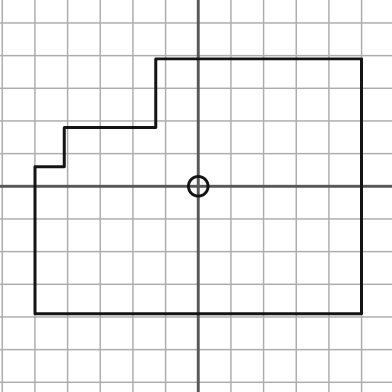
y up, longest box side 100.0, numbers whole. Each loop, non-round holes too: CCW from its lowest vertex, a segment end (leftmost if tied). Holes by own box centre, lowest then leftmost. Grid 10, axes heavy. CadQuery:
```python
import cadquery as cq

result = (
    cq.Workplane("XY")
    .moveTo(-50.0, -39.0)
    .lineTo(50.0, -39.0)
    .lineTo(50.0, 39.0)
    .lineTo(-13.0, 39.0)
    .lineTo(-13.0, 18.0)
    .lineTo(-41.0, 18.0)
    .lineTo(-41.0, 6.0)
    .lineTo(-50.0, 6.0)
    .close()
    .moveTo(0.0, 0.0)
    .circle(3.0)
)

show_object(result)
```